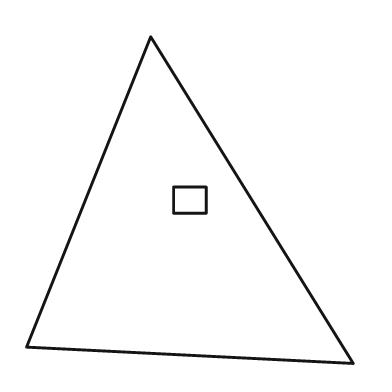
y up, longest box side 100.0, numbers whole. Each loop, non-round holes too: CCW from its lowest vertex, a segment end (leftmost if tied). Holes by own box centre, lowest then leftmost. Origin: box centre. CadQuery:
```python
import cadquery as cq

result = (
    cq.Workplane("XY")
    .moveTo(50.0, -50.0)
    .lineTo(-12.0, 50.0)
    .lineTo(-50.0, -45.0)
    .close()
    .moveTo(-5.0, -4.0)
    .lineTo(5.0, -4.0)
    .lineTo(5.0, 4.0)
    .lineTo(-5.0, 4.0)
    .close()
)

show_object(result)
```